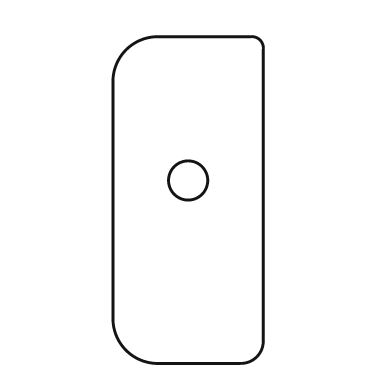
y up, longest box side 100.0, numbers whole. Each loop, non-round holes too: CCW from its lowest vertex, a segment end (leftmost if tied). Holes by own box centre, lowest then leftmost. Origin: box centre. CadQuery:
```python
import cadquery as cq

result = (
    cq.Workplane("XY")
    .moveTo(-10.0, -50.0)
    .lineTo(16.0, -50.0)
    .threePointArc((21.0, -48.0), (23.0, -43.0))
    .lineTo(23.0, 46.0)
    .threePointArc((22.0, 49.0), (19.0, 50.0))
    .lineTo(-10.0, 50.0)
    .threePointArc((-19.0, 46.0), (-23.0, 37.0))
    .lineTo(-23.0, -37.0)
    .threePointArc((-19.0, -46.0), (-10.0, -50.0))
    .close()
    .moveTo(0.0, 6.0)
    .circle(6.0)
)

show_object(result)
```